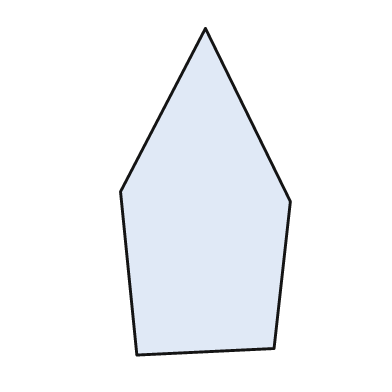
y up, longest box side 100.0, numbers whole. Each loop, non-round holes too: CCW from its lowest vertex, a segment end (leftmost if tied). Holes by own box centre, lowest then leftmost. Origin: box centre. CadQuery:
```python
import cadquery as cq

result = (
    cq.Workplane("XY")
    .moveTo(-21.0, -50.0)
    .lineTo(21.0, -48.0)
    .lineTo(26.0, -3.0)
    .lineTo(0.0, 50.0)
    .lineTo(-26.0, 0.0)
    .close()
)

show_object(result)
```